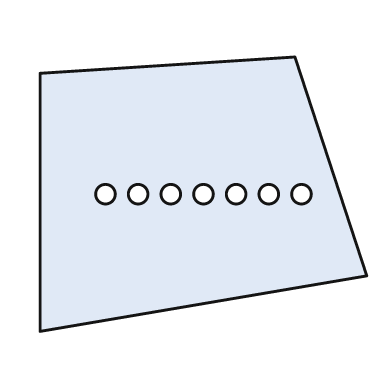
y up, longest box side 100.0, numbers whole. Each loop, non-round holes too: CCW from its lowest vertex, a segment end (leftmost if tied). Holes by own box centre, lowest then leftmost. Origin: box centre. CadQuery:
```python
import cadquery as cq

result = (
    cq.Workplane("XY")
    .moveTo(-50.0, -42.0)
    .lineTo(50.0, -25.0)
    .lineTo(28.0, 42.0)
    .lineTo(-50.0, 37.0)
    .close()
    .moveTo(-30.0, 0.0)
    .circle(3.0)
    .moveTo(-20.0, 0.0)
    .circle(3.0)
    .moveTo(-10.0, 0.0)
    .circle(3.0)
    .moveTo(0.0, 0.0)
    .circle(3.0)
    .moveTo(10.0, 0.0)
    .circle(3.0)
    .moveTo(20.0, 0.0)
    .circle(3.0)
    .moveTo(30.0, 0.0)
    .circle(3.0)
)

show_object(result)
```